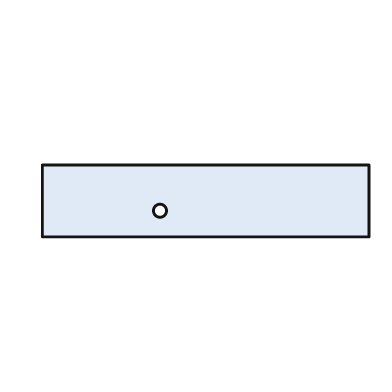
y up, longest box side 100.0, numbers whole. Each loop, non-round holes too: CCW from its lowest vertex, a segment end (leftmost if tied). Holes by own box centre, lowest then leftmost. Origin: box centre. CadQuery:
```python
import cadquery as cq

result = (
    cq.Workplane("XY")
    .moveTo(-50.0, -11.0)
    .lineTo(50.0, -11.0)
    .lineTo(50.0, 11.0)
    .lineTo(-50.0, 11.0)
    .close()
    .moveTo(-14.0, -3.0)
    .circle(2.0)
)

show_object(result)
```